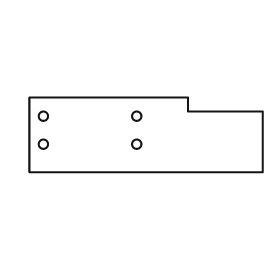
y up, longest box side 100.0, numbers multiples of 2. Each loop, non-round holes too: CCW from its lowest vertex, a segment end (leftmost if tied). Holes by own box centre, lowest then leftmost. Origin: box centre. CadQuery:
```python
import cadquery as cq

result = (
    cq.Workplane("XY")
    .moveTo(-50.0, -16.0)
    .lineTo(50.0, -16.0)
    .lineTo(50.0, 10.0)
    .lineTo(18.0, 10.0)
    .lineTo(18.0, 16.0)
    .lineTo(-50.0, 16.0)
    .close()
    .moveTo(-44.0, -4.0)
    .circle(2.0)
    .moveTo(-4.0, -4.0)
    .circle(2.0)
    .moveTo(-44.0, 8.0)
    .circle(2.0)
    .moveTo(-4.0, 8.0)
    .circle(2.0)
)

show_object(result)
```